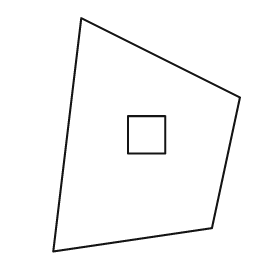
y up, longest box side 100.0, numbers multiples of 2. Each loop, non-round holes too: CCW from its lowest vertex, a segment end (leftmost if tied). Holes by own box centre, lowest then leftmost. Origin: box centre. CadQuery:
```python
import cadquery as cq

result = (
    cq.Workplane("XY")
    .moveTo(-40.0, -50.0)
    .lineTo(28.0, -40.0)
    .lineTo(40.0, 16.0)
    .lineTo(-28.0, 50.0)
    .close()
    .moveTo(-8.0, -8.0)
    .lineTo(8.0, -8.0)
    .lineTo(8.0, 8.0)
    .lineTo(-8.0, 8.0)
    .close()
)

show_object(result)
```